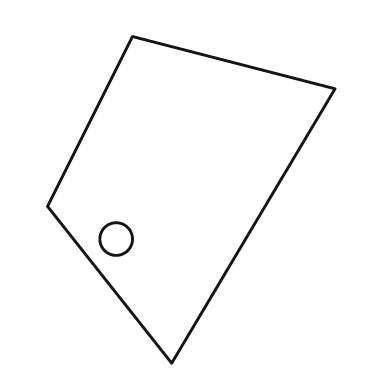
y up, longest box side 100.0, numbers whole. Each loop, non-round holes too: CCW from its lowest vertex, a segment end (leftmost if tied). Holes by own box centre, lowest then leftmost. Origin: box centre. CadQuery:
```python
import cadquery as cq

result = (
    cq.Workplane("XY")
    .moveTo(-6.0, -50.0)
    .lineTo(44.0, 34.0)
    .lineTo(-18.0, 50.0)
    .lineTo(-44.0, -2.0)
    .close()
    .moveTo(-23.0, -12.0)
    .circle(5.0)
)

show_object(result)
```